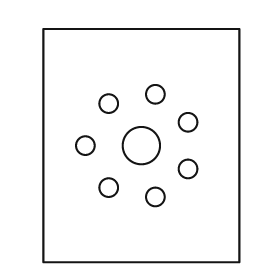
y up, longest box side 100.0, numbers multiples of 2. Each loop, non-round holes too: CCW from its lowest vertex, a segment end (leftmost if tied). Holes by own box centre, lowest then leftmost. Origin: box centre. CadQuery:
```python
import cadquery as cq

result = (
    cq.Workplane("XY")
    .moveTo(-42.0, -50.0)
    .lineTo(42.0, -50.0)
    .lineTo(42.0, 50.0)
    .lineTo(-42.0, 50.0)
    .close()
    .moveTo(6.0, -22.0)
    .circle(4.0)
    .moveTo(-14.0, -18.0)
    .circle(4.0)
    .moveTo(20.0, -10.0)
    .circle(4.0)
    .moveTo(-24.0, 0.0)
    .circle(4.0)
    .moveTo(0.0, 0.0)
    .circle(8.0)
    .moveTo(20.0, 10.0)
    .circle(4.0)
    .moveTo(-14.0, 18.0)
    .circle(4.0)
    .moveTo(6.0, 22.0)
    .circle(4.0)
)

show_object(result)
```